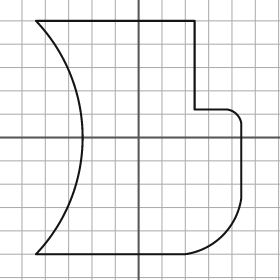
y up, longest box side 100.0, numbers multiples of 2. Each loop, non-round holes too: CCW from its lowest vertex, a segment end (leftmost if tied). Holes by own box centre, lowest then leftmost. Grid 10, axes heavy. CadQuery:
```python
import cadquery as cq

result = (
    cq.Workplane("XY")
    .moveTo(-44.0, -50.0)
    .lineTo(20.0, -50.0)
    .threePointArc((36.0, -42.0), (44.0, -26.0))
    .lineTo(44.0, 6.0)
    .threePointArc((42.0, 10.0), (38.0, 12.0))
    .lineTo(24.0, 12.0)
    .lineTo(24.0, 50.0)
    .lineTo(-44.0, 50.0)
    .threePointArc((-24.0, 0.0), (-44.0, -50.0))
    .close()
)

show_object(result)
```